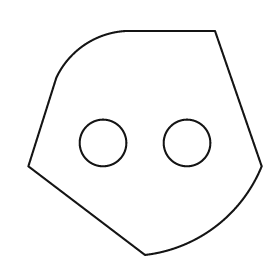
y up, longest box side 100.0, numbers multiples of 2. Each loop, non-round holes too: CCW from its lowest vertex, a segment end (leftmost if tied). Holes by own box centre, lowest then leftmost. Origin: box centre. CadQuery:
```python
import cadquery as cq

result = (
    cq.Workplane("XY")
    .moveTo(0.0, -48.0)
    .threePointArc((30.0, -36.0), (50.0, -10.0))
    .lineTo(30.0, 48.0)
    .lineTo(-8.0, 48.0)
    .threePointArc((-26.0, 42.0), (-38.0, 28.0))
    .lineTo(-50.0, -10.0)
    .close()
    .moveTo(-18.0, 0.0)
    .circle(10.0)
    .moveTo(18.0, 0.0)
    .circle(10.0)
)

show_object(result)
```